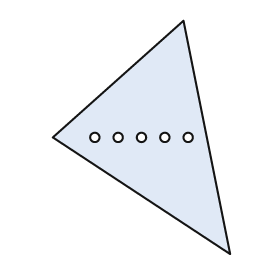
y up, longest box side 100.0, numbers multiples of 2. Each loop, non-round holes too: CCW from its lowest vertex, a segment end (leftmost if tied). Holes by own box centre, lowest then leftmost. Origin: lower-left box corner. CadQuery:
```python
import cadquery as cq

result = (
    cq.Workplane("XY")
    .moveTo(76.0, 0.0)
    .lineTo(56.0, 100.0)
    .lineTo(0.0, 50.0)
    .close()
    .moveTo(18.0, 50.0)
    .circle(2.0)
    .moveTo(28.0, 50.0)
    .circle(2.0)
    .moveTo(38.0, 50.0)
    .circle(2.0)
    .moveTo(48.0, 50.0)
    .circle(2.0)
    .moveTo(58.0, 50.0)
    .circle(2.0)
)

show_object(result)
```